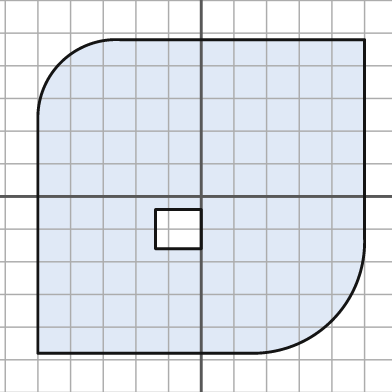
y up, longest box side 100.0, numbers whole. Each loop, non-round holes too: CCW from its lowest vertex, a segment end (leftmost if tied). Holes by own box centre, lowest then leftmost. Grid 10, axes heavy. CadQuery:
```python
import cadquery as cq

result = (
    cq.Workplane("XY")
    .moveTo(-50.0, -48.0)
    .lineTo(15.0, -48.0)
    .threePointArc((40.0, -38.0), (50.0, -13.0))
    .lineTo(50.0, 48.0)
    .lineTo(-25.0, 48.0)
    .threePointArc((-43.0, 41.0), (-50.0, 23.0))
    .close()
    .moveTo(-14.0, -16.0)
    .lineTo(0.0, -16.0)
    .lineTo(0.0, -4.0)
    .lineTo(-14.0, -4.0)
    .close()
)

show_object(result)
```